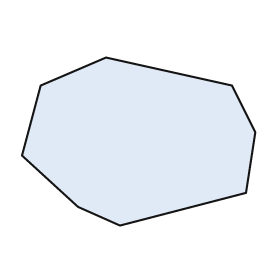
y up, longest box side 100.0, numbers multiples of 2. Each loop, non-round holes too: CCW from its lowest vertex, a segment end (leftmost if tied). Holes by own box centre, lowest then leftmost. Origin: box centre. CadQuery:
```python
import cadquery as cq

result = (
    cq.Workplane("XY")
    .moveTo(-8.0, -36.0)
    .lineTo(46.0, -22.0)
    .lineTo(50.0, 4.0)
    .lineTo(40.0, 24.0)
    .lineTo(-14.0, 36.0)
    .lineTo(-42.0, 24.0)
    .lineTo(-50.0, -6.0)
    .lineTo(-26.0, -28.0)
    .close()
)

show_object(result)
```